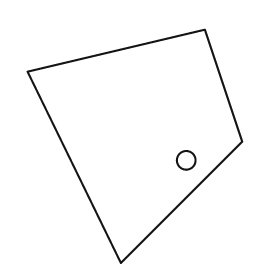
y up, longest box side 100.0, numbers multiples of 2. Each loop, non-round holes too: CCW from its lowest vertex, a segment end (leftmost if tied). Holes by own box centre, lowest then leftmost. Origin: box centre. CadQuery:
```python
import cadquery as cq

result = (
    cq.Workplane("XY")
    .moveTo(-6.0, -50.0)
    .lineTo(46.0, 2.0)
    .lineTo(30.0, 50.0)
    .lineTo(-46.0, 32.0)
    .close()
    .moveTo(22.0, -6.0)
    .circle(4.0)
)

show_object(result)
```